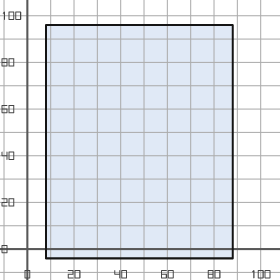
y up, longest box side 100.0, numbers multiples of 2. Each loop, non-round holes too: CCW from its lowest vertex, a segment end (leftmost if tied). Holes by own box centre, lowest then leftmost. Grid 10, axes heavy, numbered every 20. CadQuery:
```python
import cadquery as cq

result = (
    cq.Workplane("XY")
    .moveTo(8.0, -4.0)
    .lineTo(88.0, -4.0)
    .lineTo(88.0, 96.0)
    .lineTo(8.0, 96.0)
    .close()
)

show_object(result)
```